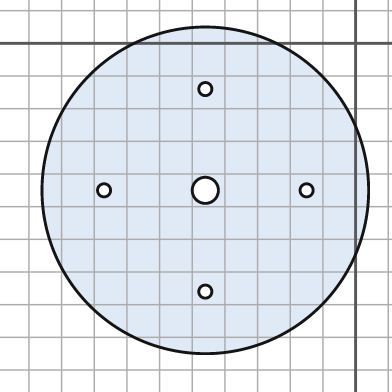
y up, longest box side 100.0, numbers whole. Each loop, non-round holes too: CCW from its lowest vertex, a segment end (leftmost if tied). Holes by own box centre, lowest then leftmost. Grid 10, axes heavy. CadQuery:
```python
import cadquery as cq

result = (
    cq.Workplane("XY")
    .moveTo(-46.0, -45.0)
    .circle(50.0)
    .moveTo(-46.0, -76.0)
    .circle(2.0)
    .moveTo(-77.0, -45.0)
    .circle(2.0)
    .moveTo(-46.0, -45.0)
    .circle(4.0)
    .moveTo(-15.0, -45.0)
    .circle(2.0)
    .moveTo(-46.0, -14.0)
    .circle(2.0)
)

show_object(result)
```